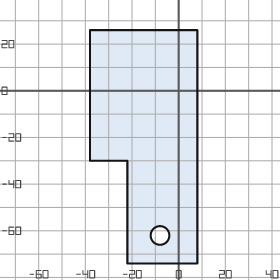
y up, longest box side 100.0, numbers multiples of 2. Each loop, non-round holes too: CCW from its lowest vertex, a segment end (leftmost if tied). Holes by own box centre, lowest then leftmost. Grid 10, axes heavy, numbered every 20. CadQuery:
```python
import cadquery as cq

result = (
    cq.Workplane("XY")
    .moveTo(-22.0, -74.0)
    .lineTo(8.0, -74.0)
    .lineTo(8.0, 26.0)
    .lineTo(-38.0, 26.0)
    .lineTo(-38.0, -30.0)
    .lineTo(-22.0, -30.0)
    .close()
    .moveTo(-8.0, -62.0)
    .circle(4.0)
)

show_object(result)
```